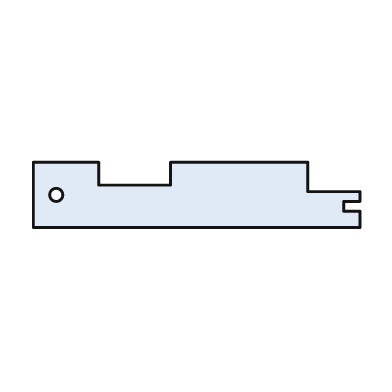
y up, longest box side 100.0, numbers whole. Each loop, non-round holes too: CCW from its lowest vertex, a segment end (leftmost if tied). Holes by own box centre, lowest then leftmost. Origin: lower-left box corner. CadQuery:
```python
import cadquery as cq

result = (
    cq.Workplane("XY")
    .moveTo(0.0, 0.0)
    .lineTo(100.0, 0.0)
    .lineTo(100.0, 5.0)
    .lineTo(95.0, 5.0)
    .lineTo(95.0, 8.0)
    .lineTo(100.0, 8.0)
    .lineTo(100.0, 11.0)
    .lineTo(84.0, 11.0)
    .lineTo(84.0, 20.0)
    .lineTo(42.0, 20.0)
    .lineTo(42.0, 13.0)
    .lineTo(20.0, 13.0)
    .lineTo(20.0, 20.0)
    .lineTo(0.0, 20.0)
    .close()
    .moveTo(7.0, 10.0)
    .circle(2.0)
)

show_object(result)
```